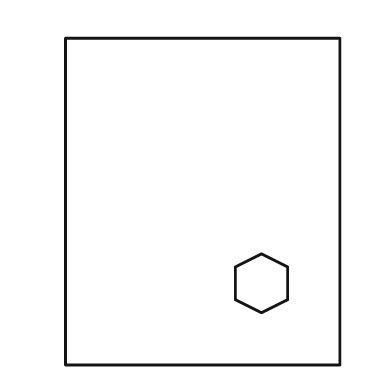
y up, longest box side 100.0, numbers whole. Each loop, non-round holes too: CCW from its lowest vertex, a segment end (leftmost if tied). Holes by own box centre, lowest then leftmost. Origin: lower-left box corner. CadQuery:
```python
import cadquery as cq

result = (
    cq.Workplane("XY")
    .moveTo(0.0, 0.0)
    .lineTo(84.0, 0.0)
    .lineTo(84.0, 100.0)
    .lineTo(0.0, 100.0)
    .close()
    .moveTo(60.0, 16.0)
    .lineTo(68.0, 20.0)
    .lineTo(68.0, 30.0)
    .lineTo(60.0, 34.0)
    .lineTo(52.0, 30.0)
    .lineTo(52.0, 20.0)
    .close()
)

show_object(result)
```